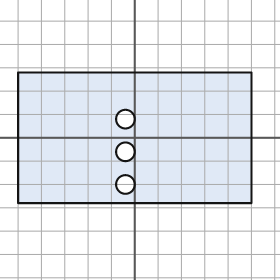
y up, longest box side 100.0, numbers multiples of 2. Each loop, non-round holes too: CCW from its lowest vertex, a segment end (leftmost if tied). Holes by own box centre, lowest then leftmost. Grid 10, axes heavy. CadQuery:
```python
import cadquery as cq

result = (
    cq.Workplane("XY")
    .moveTo(-50.0, -28.0)
    .lineTo(50.0, -28.0)
    .lineTo(50.0, 28.0)
    .lineTo(-50.0, 28.0)
    .close()
    .moveTo(-4.0, -20.0)
    .circle(4.0)
    .moveTo(-4.0, -6.0)
    .circle(4.0)
    .moveTo(-4.0, 8.0)
    .circle(4.0)
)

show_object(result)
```